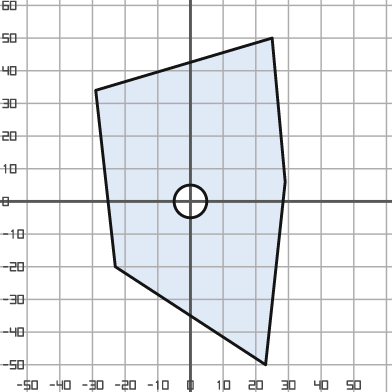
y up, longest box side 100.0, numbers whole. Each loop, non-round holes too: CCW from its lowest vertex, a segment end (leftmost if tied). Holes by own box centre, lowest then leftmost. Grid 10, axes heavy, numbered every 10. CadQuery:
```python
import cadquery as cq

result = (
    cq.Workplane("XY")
    .moveTo(23.0, -50.0)
    .lineTo(29.0, 6.0)
    .lineTo(25.0, 50.0)
    .lineTo(-29.0, 34.0)
    .lineTo(-23.0, -20.0)
    .close()
    .moveTo(0.0, 0.0)
    .circle(5.0)
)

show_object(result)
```